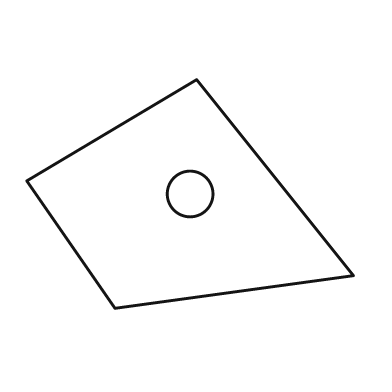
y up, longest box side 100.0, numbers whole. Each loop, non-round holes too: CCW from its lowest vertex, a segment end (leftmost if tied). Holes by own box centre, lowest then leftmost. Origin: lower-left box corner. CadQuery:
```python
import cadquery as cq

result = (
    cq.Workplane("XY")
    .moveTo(27.0, 0.0)
    .lineTo(100.0, 10.0)
    .lineTo(52.0, 70.0)
    .lineTo(0.0, 39.0)
    .close()
    .moveTo(50.0, 35.0)
    .circle(7.0)
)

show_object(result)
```